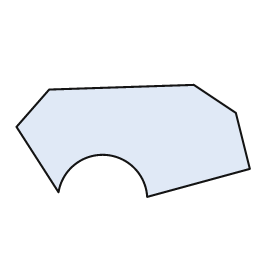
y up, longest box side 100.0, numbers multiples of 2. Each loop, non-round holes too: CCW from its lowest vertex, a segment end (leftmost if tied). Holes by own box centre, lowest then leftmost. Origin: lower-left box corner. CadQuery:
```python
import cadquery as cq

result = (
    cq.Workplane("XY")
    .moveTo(56.0, 0.0)
    .lineTo(100.0, 12.0)
    .lineTo(94.0, 36.0)
    .lineTo(76.0, 48.0)
    .lineTo(14.0, 46.0)
    .lineTo(0.0, 30.0)
    .lineTo(18.0, 2.0)
    .threePointArc((38.0, 18.0), (56.0, 0.0))
    .close()
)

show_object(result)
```